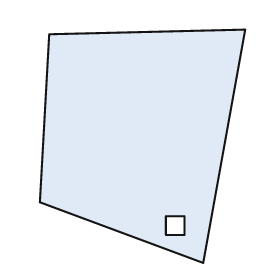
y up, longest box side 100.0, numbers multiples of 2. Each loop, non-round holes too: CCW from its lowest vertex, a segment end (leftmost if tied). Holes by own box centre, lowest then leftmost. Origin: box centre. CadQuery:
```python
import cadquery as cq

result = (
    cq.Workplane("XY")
    .moveTo(26.0, -50.0)
    .lineTo(44.0, 50.0)
    .lineTo(-40.0, 48.0)
    .lineTo(-44.0, -24.0)
    .close()
    .moveTo(10.0, -38.0)
    .lineTo(18.0, -38.0)
    .lineTo(18.0, -30.0)
    .lineTo(10.0, -30.0)
    .close()
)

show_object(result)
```